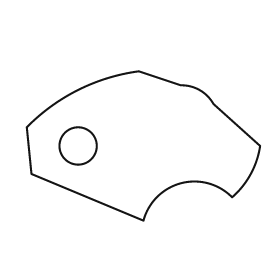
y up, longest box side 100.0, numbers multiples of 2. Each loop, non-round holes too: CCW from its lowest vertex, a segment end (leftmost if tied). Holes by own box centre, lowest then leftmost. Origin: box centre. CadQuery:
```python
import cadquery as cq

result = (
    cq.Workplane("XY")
    .moveTo(0.0, -32.0)
    .threePointArc((16.0, -16.0), (38.0, -22.0))
    .threePointArc((46.0, -12.0), (50.0, 0.0))
    .lineTo(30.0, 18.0)
    .threePointArc((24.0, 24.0), (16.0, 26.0))
    .lineTo(-2.0, 32.0)
    .threePointArc((-28.0, 24.0), (-50.0, 8.0))
    .lineTo(-48.0, -12.0)
    .close()
    .moveTo(-28.0, 0.0)
    .circle(8.0)
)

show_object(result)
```